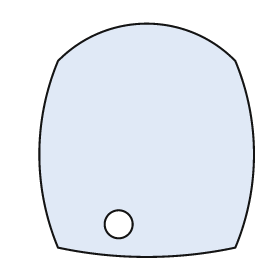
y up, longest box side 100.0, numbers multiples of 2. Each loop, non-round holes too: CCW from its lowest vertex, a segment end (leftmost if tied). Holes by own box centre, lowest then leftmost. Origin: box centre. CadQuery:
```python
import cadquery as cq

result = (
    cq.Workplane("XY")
    .moveTo(-38.0, -46.0)
    .threePointArc((0.0, -50.0), (38.0, -46.0))
    .threePointArc((46.0, -6.0), (38.0, 34.0))
    .threePointArc((0.0, 50.0), (-38.0, 34.0))
    .threePointArc((-46.0, -6.0), (-38.0, -46.0))
    .close()
    .moveTo(-12.0, -36.0)
    .circle(6.0)
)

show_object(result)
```